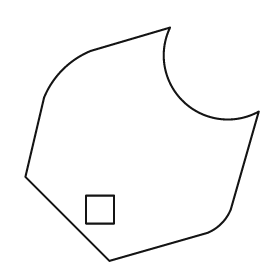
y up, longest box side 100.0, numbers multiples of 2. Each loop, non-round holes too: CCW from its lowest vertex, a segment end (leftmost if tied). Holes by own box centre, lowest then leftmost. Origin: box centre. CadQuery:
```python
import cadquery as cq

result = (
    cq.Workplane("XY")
    .moveTo(-14.0, -50.0)
    .lineTo(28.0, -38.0)
    .threePointArc((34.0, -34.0), (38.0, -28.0))
    .lineTo(50.0, 14.0)
    .threePointArc((18.0, 18.0), (12.0, 50.0))
    .lineTo(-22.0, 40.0)
    .threePointArc((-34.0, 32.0), (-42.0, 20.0))
    .lineTo(-50.0, -14.0)
    .close()
    .moveTo(-24.0, -34.0)
    .lineTo(-12.0, -34.0)
    .lineTo(-12.0, -22.0)
    .lineTo(-24.0, -22.0)
    .close()
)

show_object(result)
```